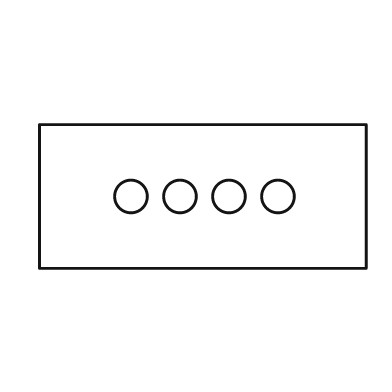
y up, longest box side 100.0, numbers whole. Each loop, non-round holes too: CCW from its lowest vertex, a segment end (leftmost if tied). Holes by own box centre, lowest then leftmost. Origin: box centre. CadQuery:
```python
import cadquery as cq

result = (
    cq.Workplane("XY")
    .moveTo(-50.0, -22.0)
    .lineTo(50.0, -22.0)
    .lineTo(50.0, 22.0)
    .lineTo(-50.0, 22.0)
    .close()
    .moveTo(-22.0, 0.0)
    .circle(5.0)
    .moveTo(-7.0, 0.0)
    .circle(5.0)
    .moveTo(8.0, 0.0)
    .circle(5.0)
    .moveTo(23.0, 0.0)
    .circle(5.0)
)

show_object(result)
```